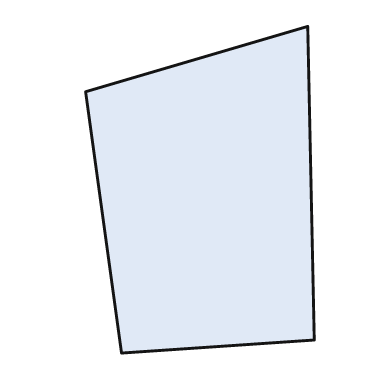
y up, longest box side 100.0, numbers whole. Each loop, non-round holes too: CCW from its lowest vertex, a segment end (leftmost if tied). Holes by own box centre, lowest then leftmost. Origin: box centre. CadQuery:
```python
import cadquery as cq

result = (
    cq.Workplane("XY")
    .moveTo(-24.0, -50.0)
    .lineTo(35.0, -46.0)
    .lineTo(33.0, 50.0)
    .lineTo(-35.0, 30.0)
    .close()
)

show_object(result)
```